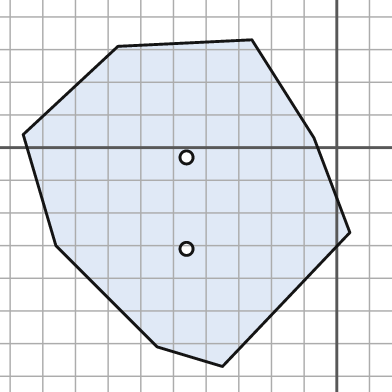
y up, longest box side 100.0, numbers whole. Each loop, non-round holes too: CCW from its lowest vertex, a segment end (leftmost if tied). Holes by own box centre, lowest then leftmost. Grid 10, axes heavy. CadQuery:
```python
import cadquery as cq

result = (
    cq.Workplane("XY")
    .moveTo(-35.0, -67.0)
    .lineTo(4.0, -26.0)
    .lineTo(-7.0, 3.0)
    .lineTo(-26.0, 33.0)
    .lineTo(-67.0, 31.0)
    .lineTo(-96.0, 4.0)
    .lineTo(-86.0, -30.0)
    .lineTo(-55.0, -61.0)
    .close()
    .moveTo(-46.0, -31.0)
    .circle(2.0)
    .moveTo(-46.0, -3.0)
    .circle(2.0)
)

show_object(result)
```